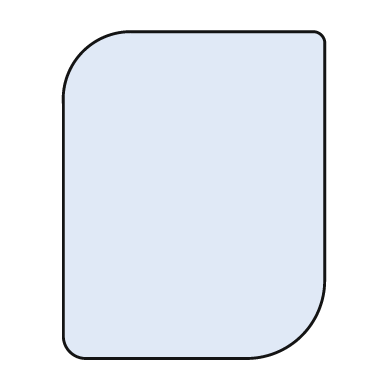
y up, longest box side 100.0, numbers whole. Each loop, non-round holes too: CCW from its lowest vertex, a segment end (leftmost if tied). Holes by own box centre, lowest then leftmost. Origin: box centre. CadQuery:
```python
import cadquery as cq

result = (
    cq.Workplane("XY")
    .moveTo(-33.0, -50.0)
    .lineTo(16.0, -50.0)
    .threePointArc((33.0, -43.0), (40.0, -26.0))
    .lineTo(40.0, 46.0)
    .threePointArc((39.0, 49.0), (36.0, 50.0))
    .lineTo(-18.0, 50.0)
    .threePointArc((-34.0, 44.0), (-40.0, 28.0))
    .lineTo(-40.0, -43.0)
    .threePointArc((-38.0, -48.0), (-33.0, -50.0))
    .close()
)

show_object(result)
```